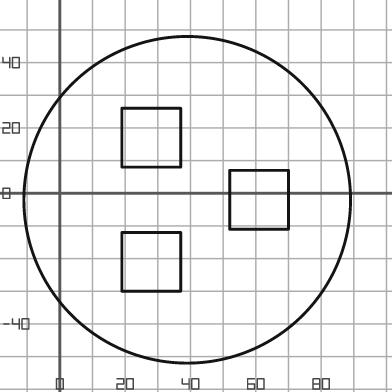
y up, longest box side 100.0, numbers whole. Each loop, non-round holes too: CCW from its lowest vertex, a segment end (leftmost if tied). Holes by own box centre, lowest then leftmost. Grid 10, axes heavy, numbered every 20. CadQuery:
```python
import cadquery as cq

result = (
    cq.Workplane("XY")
    .moveTo(39.0, -2.0)
    .circle(50.0)
    .moveTo(19.0, -30.0)
    .lineTo(37.0, -30.0)
    .lineTo(37.0, -12.0)
    .lineTo(19.0, -12.0)
    .close()
    .moveTo(52.0, -11.0)
    .lineTo(70.0, -11.0)
    .lineTo(70.0, 7.0)
    .lineTo(52.0, 7.0)
    .close()
    .moveTo(19.0, 8.0)
    .lineTo(37.0, 8.0)
    .lineTo(37.0, 26.0)
    .lineTo(19.0, 26.0)
    .close()
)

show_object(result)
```